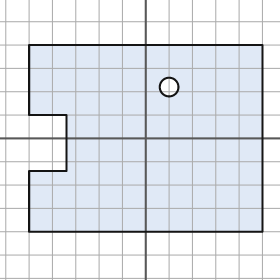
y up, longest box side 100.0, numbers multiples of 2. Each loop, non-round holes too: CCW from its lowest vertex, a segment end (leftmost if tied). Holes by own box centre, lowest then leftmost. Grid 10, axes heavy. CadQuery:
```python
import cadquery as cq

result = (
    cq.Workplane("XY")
    .moveTo(-50.0, -40.0)
    .lineTo(50.0, -40.0)
    .lineTo(50.0, 40.0)
    .lineTo(-50.0, 40.0)
    .lineTo(-50.0, 10.0)
    .lineTo(-34.0, 10.0)
    .lineTo(-34.0, -14.0)
    .lineTo(-50.0, -14.0)
    .close()
    .moveTo(10.0, 22.0)
    .circle(4.0)
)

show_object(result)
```